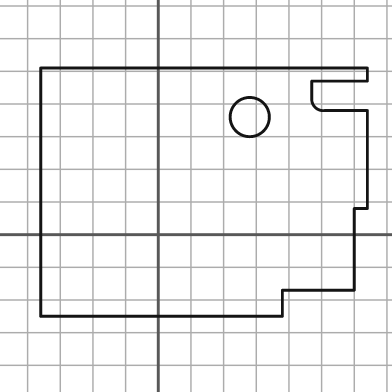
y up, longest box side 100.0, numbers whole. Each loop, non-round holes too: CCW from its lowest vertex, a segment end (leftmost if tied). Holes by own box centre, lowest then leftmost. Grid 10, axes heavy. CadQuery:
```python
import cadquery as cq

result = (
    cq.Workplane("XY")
    .moveTo(-36.0, -25.0)
    .lineTo(38.0, -25.0)
    .lineTo(38.0, -17.0)
    .lineTo(60.0, -17.0)
    .lineTo(60.0, 8.0)
    .lineTo(64.0, 8.0)
    .lineTo(64.0, 38.0)
    .lineTo(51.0, 38.0)
    .threePointArc((48.0, 39.0), (47.0, 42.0))
    .lineTo(47.0, 47.0)
    .lineTo(64.0, 47.0)
    .lineTo(64.0, 51.0)
    .lineTo(-36.0, 51.0)
    .close()
    .moveTo(28.0, 36.0)
    .circle(6.0)
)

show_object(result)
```